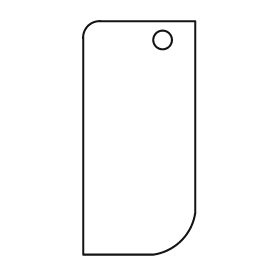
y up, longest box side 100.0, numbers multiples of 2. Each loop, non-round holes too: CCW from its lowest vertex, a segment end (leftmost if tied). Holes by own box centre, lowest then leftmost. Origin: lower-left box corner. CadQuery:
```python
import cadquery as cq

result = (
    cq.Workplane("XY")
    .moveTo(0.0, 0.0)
    .lineTo(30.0, 0.0)
    .threePointArc((42.0, 6.0), (48.0, 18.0))
    .lineTo(48.0, 100.0)
    .lineTo(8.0, 100.0)
    .threePointArc((2.0, 98.0), (0.0, 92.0))
    .close()
    .moveTo(34.0, 92.0)
    .circle(4.0)
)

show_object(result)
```